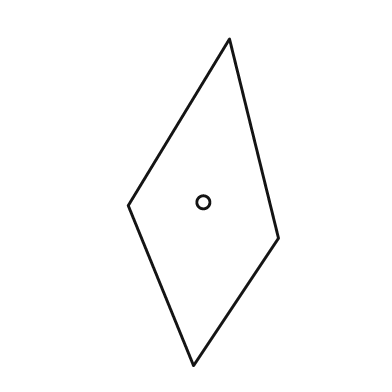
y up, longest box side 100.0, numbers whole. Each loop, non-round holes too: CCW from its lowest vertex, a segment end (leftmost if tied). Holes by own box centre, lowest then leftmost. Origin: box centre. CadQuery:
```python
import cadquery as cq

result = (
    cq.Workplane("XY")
    .moveTo(-3.0, -50.0)
    .lineTo(23.0, -11.0)
    .lineTo(8.0, 50.0)
    .lineTo(-23.0, -1.0)
    .close()
    .moveTo(0.0, 0.0)
    .circle(2.0)
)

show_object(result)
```